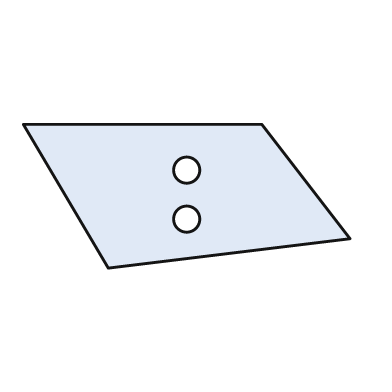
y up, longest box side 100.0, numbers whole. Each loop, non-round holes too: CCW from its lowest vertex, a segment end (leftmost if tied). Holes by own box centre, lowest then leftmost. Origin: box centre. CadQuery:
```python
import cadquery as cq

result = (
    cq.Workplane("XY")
    .moveTo(-24.0, -22.0)
    .lineTo(50.0, -13.0)
    .lineTo(23.0, 22.0)
    .lineTo(-50.0, 22.0)
    .close()
    .moveTo(0.0, -7.0)
    .circle(4.0)
    .moveTo(0.0, 8.0)
    .circle(4.0)
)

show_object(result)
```